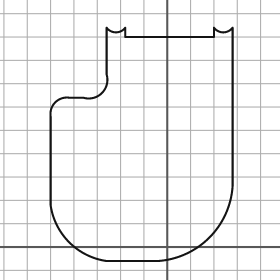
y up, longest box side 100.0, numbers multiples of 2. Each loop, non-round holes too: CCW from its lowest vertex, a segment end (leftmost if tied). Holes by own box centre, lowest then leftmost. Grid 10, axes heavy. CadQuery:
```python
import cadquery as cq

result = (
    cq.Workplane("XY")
    .moveTo(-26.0, -6.0)
    .lineTo(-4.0, -6.0)
    .threePointArc((18.0, 4.0), (28.0, 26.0))
    .lineTo(28.0, 94.0)
    .threePointArc((24.0, 92.0), (20.0, 94.0))
    .lineTo(20.0, 90.0)
    .lineTo(-18.0, 90.0)
    .lineTo(-18.0, 94.0)
    .threePointArc((-22.0, 92.0), (-26.0, 94.0))
    .lineTo(-26.0, 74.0)
    .threePointArc((-28.0, 66.0), (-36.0, 64.0))
    .lineTo(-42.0, 64.0)
    .threePointArc((-48.0, 62.0), (-50.0, 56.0))
    .lineTo(-50.0, 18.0)
    .threePointArc((-42.0, 2.0), (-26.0, -6.0))
    .close()
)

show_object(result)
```